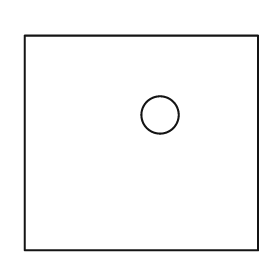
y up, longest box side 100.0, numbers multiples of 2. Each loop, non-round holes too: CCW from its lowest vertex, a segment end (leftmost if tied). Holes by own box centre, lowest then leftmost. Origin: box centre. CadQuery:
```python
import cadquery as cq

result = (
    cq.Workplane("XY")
    .moveTo(-50.0, -46.0)
    .lineTo(50.0, -46.0)
    .lineTo(50.0, 46.0)
    .lineTo(-50.0, 46.0)
    .close()
    .moveTo(8.0, 12.0)
    .circle(8.0)
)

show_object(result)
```